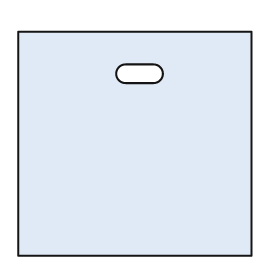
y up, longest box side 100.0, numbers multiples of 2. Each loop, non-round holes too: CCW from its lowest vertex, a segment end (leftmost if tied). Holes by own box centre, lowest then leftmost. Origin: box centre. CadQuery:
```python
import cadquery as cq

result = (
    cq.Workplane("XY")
    .moveTo(-50.0, -48.0)
    .lineTo(50.0, -48.0)
    .lineTo(50.0, 48.0)
    .lineTo(-50.0, 48.0)
    .close()
    .moveTo(-4.0, 26.0)
    .lineTo(8.0, 26.0)
    .threePointArc((12.0, 30.0), (8.0, 34.0))
    .lineTo(-4.0, 34.0)
    .threePointArc((-8.0, 30.0), (-4.0, 26.0))
    .close()
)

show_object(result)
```